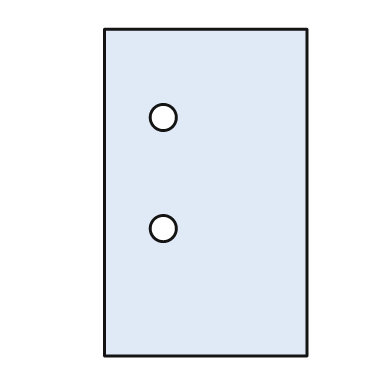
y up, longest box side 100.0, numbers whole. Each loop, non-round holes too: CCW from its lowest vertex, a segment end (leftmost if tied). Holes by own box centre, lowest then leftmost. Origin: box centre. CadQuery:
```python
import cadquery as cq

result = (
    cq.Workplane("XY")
    .moveTo(-31.0, -50.0)
    .lineTo(31.0, -50.0)
    .lineTo(31.0, 50.0)
    .lineTo(-31.0, 50.0)
    .close()
    .moveTo(-13.0, -11.0)
    .circle(4.0)
    .moveTo(-13.0, 23.0)
    .circle(4.0)
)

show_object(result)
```